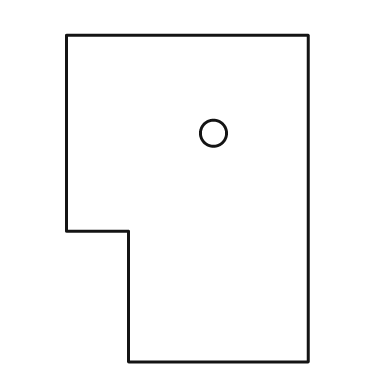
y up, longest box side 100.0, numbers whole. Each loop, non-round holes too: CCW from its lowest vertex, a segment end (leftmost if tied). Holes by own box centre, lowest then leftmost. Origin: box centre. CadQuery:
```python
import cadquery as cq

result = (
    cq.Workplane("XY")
    .moveTo(-18.0, -50.0)
    .lineTo(37.0, -50.0)
    .lineTo(37.0, 50.0)
    .lineTo(-37.0, 50.0)
    .lineTo(-37.0, -10.0)
    .lineTo(-18.0, -10.0)
    .close()
    .moveTo(8.0, 20.0)
    .circle(4.0)
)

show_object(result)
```